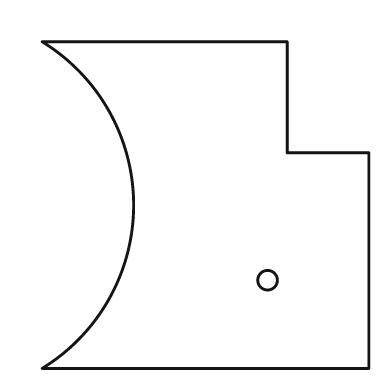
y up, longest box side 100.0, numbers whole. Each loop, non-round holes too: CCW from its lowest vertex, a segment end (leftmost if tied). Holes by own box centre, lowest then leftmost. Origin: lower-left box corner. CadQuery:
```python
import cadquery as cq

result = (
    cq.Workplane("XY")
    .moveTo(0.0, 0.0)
    .lineTo(100.0, 0.0)
    .lineTo(100.0, 66.0)
    .lineTo(75.0, 66.0)
    .lineTo(75.0, 100.0)
    .lineTo(0.0, 100.0)
    .threePointArc((28.0, 50.0), (0.0, 0.0))
    .close()
    .moveTo(69.0, 27.0)
    .circle(3.0)
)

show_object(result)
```